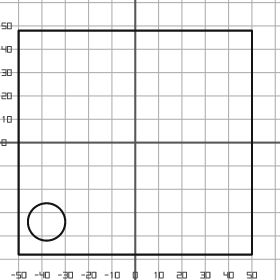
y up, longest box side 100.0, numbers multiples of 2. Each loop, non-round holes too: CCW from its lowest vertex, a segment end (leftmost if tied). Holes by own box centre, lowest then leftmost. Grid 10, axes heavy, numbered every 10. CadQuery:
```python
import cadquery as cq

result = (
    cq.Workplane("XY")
    .moveTo(-50.0, -48.0)
    .lineTo(50.0, -48.0)
    .lineTo(50.0, 48.0)
    .lineTo(-50.0, 48.0)
    .close()
    .moveTo(-38.0, -34.0)
    .circle(8.0)
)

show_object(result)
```